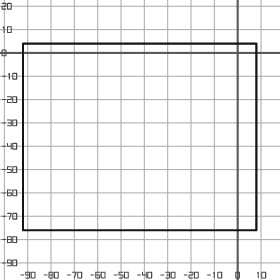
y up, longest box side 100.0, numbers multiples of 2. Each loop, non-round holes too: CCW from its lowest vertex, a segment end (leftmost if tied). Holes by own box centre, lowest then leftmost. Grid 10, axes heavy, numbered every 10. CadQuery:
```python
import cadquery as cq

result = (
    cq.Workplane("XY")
    .moveTo(-92.0, -76.0)
    .lineTo(8.0, -76.0)
    .lineTo(8.0, 4.0)
    .lineTo(-92.0, 4.0)
    .close()
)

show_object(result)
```